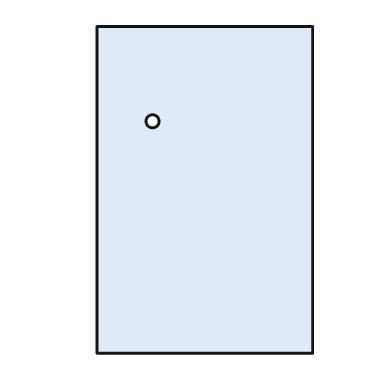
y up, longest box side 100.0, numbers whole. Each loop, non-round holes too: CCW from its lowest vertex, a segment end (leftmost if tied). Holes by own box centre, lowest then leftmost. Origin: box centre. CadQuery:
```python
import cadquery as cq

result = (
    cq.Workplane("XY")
    .moveTo(-33.0, -50.0)
    .lineTo(33.0, -50.0)
    .lineTo(33.0, 50.0)
    .lineTo(-33.0, 50.0)
    .close()
    .moveTo(-16.0, 21.0)
    .circle(2.0)
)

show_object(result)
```